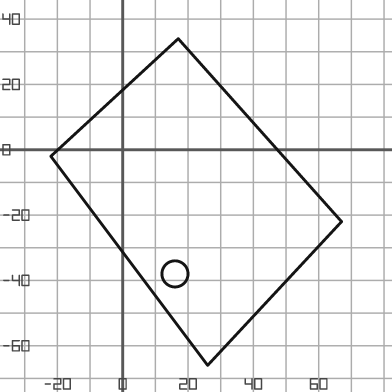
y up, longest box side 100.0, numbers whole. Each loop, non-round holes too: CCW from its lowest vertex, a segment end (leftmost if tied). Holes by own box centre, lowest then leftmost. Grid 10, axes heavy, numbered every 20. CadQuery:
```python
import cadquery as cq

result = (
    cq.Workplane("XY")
    .moveTo(26.0, -66.0)
    .lineTo(67.0, -22.0)
    .lineTo(17.0, 34.0)
    .lineTo(-22.0, -2.0)
    .close()
    .moveTo(16.0, -38.0)
    .circle(4.0)
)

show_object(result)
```